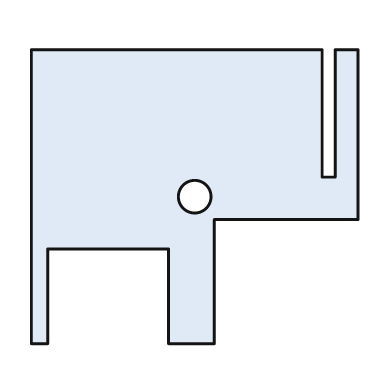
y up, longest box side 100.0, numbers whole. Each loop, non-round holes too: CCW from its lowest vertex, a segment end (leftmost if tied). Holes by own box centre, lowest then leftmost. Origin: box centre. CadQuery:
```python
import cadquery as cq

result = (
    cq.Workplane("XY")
    .moveTo(-50.0, -45.0)
    .lineTo(-45.0, -45.0)
    .lineTo(-45.0, -16.0)
    .lineTo(-8.0, -16.0)
    .lineTo(-8.0, -45.0)
    .lineTo(6.0, -45.0)
    .lineTo(6.0, -7.0)
    .lineTo(50.0, -7.0)
    .lineTo(50.0, 45.0)
    .lineTo(43.0, 45.0)
    .lineTo(43.0, 6.0)
    .lineTo(39.0, 6.0)
    .lineTo(39.0, 45.0)
    .lineTo(-50.0, 45.0)
    .close()
    .moveTo(0.0, 0.0)
    .circle(5.0)
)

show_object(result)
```